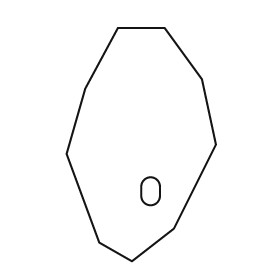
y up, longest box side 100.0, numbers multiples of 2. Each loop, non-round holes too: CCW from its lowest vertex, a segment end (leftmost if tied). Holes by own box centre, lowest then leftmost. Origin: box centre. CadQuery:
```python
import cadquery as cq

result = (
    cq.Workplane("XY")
    .moveTo(-4.0, -50.0)
    .lineTo(14.0, -36.0)
    .lineTo(32.0, 0.0)
    .lineTo(26.0, 28.0)
    .lineTo(10.0, 50.0)
    .lineTo(-10.0, 50.0)
    .lineTo(-24.0, 24.0)
    .lineTo(-32.0, -4.0)
    .lineTo(-18.0, -42.0)
    .close()
    .moveTo(0.0, -22.0)
    .threePointArc((4.0, -26.0), (8.0, -22.0))
    .lineTo(8.0, -18.0)
    .threePointArc((4.0, -14.0), (0.0, -18.0))
    .close()
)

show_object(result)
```